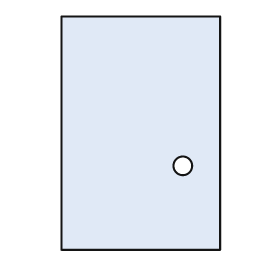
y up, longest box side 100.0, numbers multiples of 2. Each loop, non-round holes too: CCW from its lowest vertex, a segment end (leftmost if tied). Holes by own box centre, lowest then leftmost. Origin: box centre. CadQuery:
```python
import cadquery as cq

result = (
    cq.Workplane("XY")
    .moveTo(-34.0, -50.0)
    .lineTo(34.0, -50.0)
    .lineTo(34.0, 50.0)
    .lineTo(-34.0, 50.0)
    .close()
    .moveTo(18.0, -14.0)
    .circle(4.0)
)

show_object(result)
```